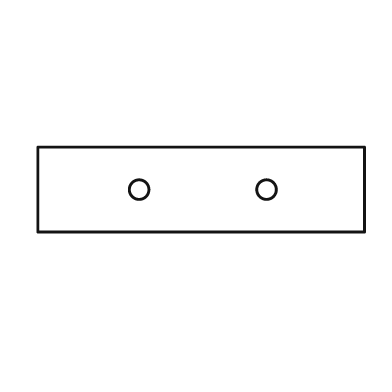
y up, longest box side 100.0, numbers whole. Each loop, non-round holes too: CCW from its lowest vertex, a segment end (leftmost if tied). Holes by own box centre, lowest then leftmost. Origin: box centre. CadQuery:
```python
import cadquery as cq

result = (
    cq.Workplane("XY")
    .moveTo(-50.0, -13.0)
    .lineTo(50.0, -13.0)
    .lineTo(50.0, 13.0)
    .lineTo(-50.0, 13.0)
    .close()
    .moveTo(-19.0, 0.0)
    .circle(3.0)
    .moveTo(20.0, 0.0)
    .circle(3.0)
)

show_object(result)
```